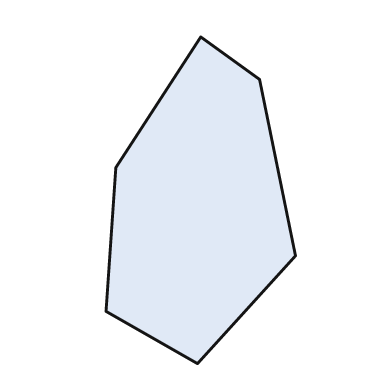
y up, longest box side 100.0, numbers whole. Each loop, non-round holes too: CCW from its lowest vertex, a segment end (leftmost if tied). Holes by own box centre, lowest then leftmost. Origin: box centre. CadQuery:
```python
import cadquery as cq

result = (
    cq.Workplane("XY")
    .moveTo(-1.0, -50.0)
    .lineTo(29.0, -17.0)
    .lineTo(18.0, 37.0)
    .lineTo(0.0, 50.0)
    .lineTo(-26.0, 10.0)
    .lineTo(-29.0, -34.0)
    .close()
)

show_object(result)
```